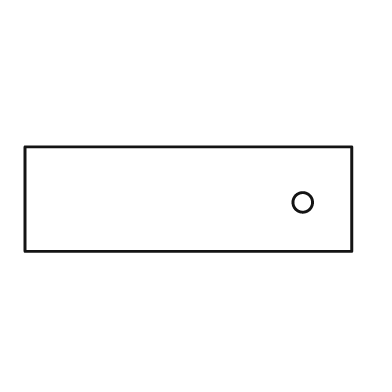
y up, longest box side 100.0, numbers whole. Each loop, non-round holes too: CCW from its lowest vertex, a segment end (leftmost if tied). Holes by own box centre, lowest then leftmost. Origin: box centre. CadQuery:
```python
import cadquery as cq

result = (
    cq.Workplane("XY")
    .moveTo(-50.0, -16.0)
    .lineTo(50.0, -16.0)
    .lineTo(50.0, 16.0)
    .lineTo(-50.0, 16.0)
    .close()
    .moveTo(35.0, -1.0)
    .circle(3.0)
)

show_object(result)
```